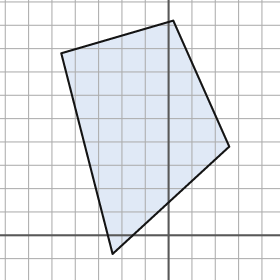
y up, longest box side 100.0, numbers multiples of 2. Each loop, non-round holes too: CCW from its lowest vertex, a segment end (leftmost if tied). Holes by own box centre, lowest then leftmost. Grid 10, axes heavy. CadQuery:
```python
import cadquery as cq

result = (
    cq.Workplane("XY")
    .moveTo(-24.0, -8.0)
    .lineTo(26.0, 38.0)
    .lineTo(2.0, 92.0)
    .lineTo(-46.0, 78.0)
    .close()
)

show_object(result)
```